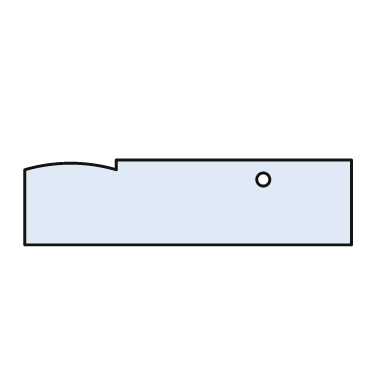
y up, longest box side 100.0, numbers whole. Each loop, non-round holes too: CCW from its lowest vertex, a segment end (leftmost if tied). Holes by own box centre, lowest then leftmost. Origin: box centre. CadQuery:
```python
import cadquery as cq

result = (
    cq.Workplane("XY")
    .moveTo(-50.0, -13.0)
    .lineTo(50.0, -13.0)
    .lineTo(50.0, 13.0)
    .lineTo(-22.0, 13.0)
    .lineTo(-22.0, 10.0)
    .threePointArc((-36.0, 12.0), (-50.0, 10.0))
    .close()
    .moveTo(23.0, 7.0)
    .circle(2.0)
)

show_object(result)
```